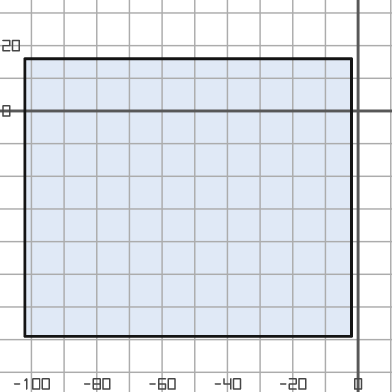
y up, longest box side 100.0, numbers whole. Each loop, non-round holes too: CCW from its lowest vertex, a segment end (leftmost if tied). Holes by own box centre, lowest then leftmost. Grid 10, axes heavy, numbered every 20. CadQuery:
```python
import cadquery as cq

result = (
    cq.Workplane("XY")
    .moveTo(-102.0, -69.0)
    .lineTo(-2.0, -69.0)
    .lineTo(-2.0, 16.0)
    .lineTo(-102.0, 16.0)
    .close()
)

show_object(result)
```